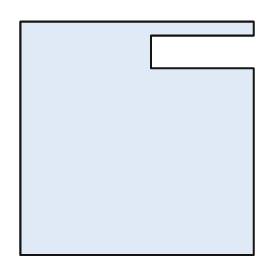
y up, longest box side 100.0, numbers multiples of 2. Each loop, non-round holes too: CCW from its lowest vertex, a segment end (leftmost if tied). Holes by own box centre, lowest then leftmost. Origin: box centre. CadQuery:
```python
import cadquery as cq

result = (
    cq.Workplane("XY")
    .moveTo(-50.0, -50.0)
    .lineTo(50.0, -50.0)
    .lineTo(50.0, 30.0)
    .lineTo(6.0, 30.0)
    .lineTo(6.0, 44.0)
    .lineTo(50.0, 44.0)
    .lineTo(50.0, 50.0)
    .lineTo(-50.0, 50.0)
    .close()
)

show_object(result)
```